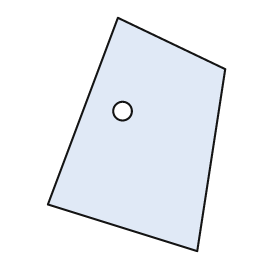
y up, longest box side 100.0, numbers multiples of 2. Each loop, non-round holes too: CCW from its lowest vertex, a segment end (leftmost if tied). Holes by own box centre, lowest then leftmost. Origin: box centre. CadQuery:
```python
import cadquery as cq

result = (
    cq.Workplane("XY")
    .moveTo(26.0, -50.0)
    .lineTo(38.0, 28.0)
    .lineTo(-8.0, 50.0)
    .lineTo(-38.0, -30.0)
    .close()
    .moveTo(-6.0, 10.0)
    .circle(4.0)
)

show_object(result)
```